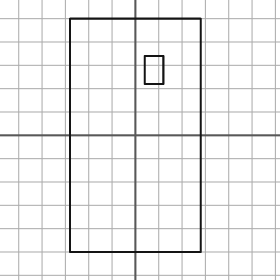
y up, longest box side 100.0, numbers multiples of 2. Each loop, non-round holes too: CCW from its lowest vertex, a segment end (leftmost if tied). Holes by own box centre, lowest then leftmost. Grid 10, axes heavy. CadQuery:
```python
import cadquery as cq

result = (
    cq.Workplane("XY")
    .moveTo(-28.0, -50.0)
    .lineTo(28.0, -50.0)
    .lineTo(28.0, 50.0)
    .lineTo(-28.0, 50.0)
    .close()
    .moveTo(4.0, 22.0)
    .lineTo(12.0, 22.0)
    .lineTo(12.0, 34.0)
    .lineTo(4.0, 34.0)
    .close()
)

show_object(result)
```